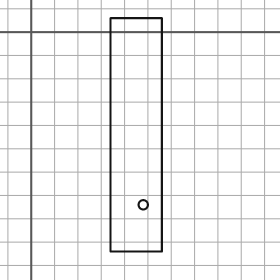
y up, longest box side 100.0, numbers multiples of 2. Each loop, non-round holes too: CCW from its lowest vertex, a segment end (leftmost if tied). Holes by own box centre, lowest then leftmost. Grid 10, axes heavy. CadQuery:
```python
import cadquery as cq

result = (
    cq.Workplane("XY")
    .moveTo(34.0, -94.0)
    .lineTo(56.0, -94.0)
    .lineTo(56.0, 6.0)
    .lineTo(34.0, 6.0)
    .close()
    .moveTo(48.0, -74.0)
    .circle(2.0)
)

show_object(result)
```